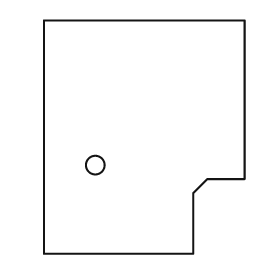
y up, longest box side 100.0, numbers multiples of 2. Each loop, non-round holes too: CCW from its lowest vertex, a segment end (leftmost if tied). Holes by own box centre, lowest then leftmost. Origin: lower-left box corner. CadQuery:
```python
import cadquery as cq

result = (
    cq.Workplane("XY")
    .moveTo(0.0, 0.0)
    .lineTo(64.0, 0.0)
    .lineTo(64.0, 26.0)
    .lineTo(70.0, 32.0)
    .lineTo(86.0, 32.0)
    .lineTo(86.0, 100.0)
    .lineTo(0.0, 100.0)
    .close()
    .moveTo(22.0, 38.0)
    .circle(4.0)
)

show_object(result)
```